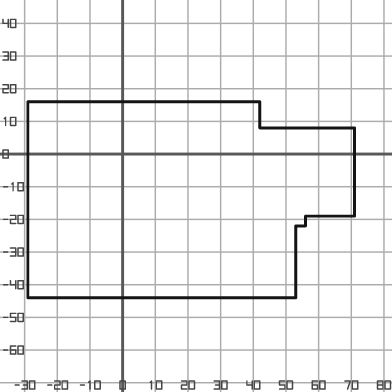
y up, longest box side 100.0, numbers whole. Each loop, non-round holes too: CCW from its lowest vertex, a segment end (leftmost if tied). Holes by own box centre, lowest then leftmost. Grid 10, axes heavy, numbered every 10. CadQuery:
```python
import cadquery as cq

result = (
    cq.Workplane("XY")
    .moveTo(-29.0, -44.0)
    .lineTo(53.0, -44.0)
    .lineTo(53.0, -22.0)
    .lineTo(56.0, -22.0)
    .lineTo(56.0, -19.0)
    .lineTo(71.0, -19.0)
    .lineTo(71.0, 8.0)
    .lineTo(42.0, 8.0)
    .lineTo(42.0, 16.0)
    .lineTo(-29.0, 16.0)
    .close()
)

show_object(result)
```